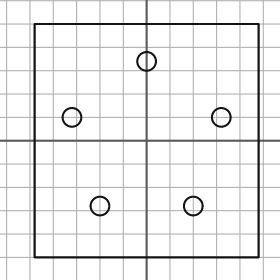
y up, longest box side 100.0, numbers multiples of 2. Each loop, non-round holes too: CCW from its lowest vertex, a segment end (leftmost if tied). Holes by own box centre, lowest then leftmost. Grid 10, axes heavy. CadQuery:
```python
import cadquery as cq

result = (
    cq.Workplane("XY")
    .moveTo(-48.0, -50.0)
    .lineTo(48.0, -50.0)
    .lineTo(48.0, 50.0)
    .lineTo(-48.0, 50.0)
    .close()
    .moveTo(-20.0, -28.0)
    .circle(4.0)
    .moveTo(20.0, -28.0)
    .circle(4.0)
    .moveTo(-32.0, 10.0)
    .circle(4.0)
    .moveTo(32.0, 10.0)
    .circle(4.0)
    .moveTo(0.0, 34.0)
    .circle(4.0)
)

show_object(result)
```